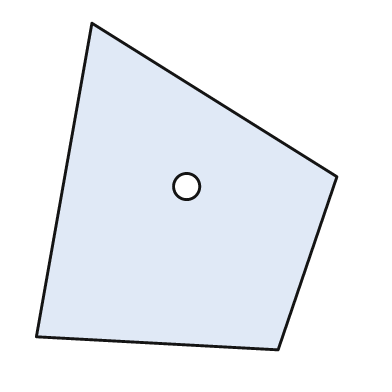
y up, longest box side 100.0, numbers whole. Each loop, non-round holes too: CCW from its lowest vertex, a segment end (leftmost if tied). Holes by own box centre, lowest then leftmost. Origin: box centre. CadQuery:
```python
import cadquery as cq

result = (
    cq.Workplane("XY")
    .moveTo(28.0, -50.0)
    .lineTo(46.0, 3.0)
    .lineTo(-29.0, 50.0)
    .lineTo(-46.0, -46.0)
    .close()
    .moveTo(0.0, 0.0)
    .circle(4.0)
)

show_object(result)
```